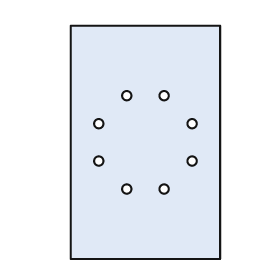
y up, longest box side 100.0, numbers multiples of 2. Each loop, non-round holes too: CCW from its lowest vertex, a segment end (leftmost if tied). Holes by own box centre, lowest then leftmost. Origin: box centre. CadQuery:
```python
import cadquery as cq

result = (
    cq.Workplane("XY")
    .moveTo(-32.0, -50.0)
    .lineTo(32.0, -50.0)
    .lineTo(32.0, 50.0)
    .lineTo(-32.0, 50.0)
    .close()
    .moveTo(-8.0, -20.0)
    .circle(2.0)
    .moveTo(8.0, -20.0)
    .circle(2.0)
    .moveTo(-20.0, -8.0)
    .circle(2.0)
    .moveTo(20.0, -8.0)
    .circle(2.0)
    .moveTo(-20.0, 8.0)
    .circle(2.0)
    .moveTo(20.0, 8.0)
    .circle(2.0)
    .moveTo(-8.0, 20.0)
    .circle(2.0)
    .moveTo(8.0, 20.0)
    .circle(2.0)
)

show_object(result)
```